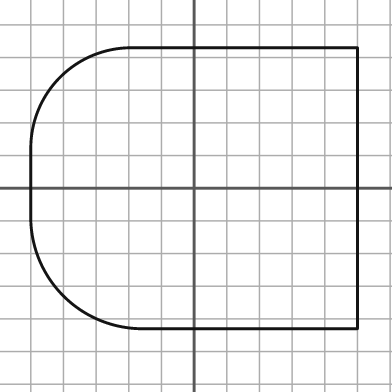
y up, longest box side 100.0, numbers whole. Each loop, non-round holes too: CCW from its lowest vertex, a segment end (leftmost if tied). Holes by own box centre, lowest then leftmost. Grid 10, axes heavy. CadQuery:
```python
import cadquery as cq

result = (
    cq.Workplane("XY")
    .moveTo(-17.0, -43.0)
    .lineTo(50.0, -43.0)
    .lineTo(50.0, 43.0)
    .lineTo(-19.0, 43.0)
    .threePointArc((-41.0, 34.0), (-50.0, 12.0))
    .lineTo(-50.0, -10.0)
    .threePointArc((-40.0, -33.0), (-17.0, -43.0))
    .close()
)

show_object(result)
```